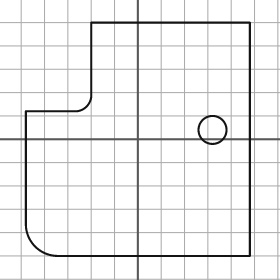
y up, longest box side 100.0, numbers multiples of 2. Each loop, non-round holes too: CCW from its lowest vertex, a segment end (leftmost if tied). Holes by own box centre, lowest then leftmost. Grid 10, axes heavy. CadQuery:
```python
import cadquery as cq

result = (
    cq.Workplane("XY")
    .moveTo(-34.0, -50.0)
    .lineTo(48.0, -50.0)
    .lineTo(48.0, 50.0)
    .lineTo(-20.0, 50.0)
    .lineTo(-20.0, 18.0)
    .threePointArc((-22.0, 14.0), (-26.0, 12.0))
    .lineTo(-48.0, 12.0)
    .lineTo(-48.0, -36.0)
    .threePointArc((-44.0, -46.0), (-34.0, -50.0))
    .close()
    .moveTo(32.0, 4.0)
    .circle(6.0)
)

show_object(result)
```